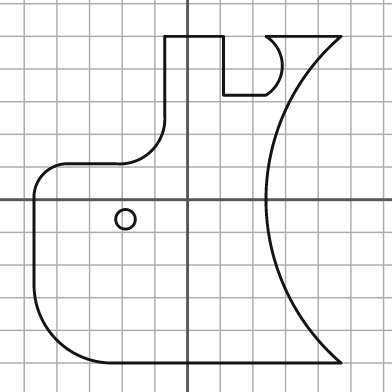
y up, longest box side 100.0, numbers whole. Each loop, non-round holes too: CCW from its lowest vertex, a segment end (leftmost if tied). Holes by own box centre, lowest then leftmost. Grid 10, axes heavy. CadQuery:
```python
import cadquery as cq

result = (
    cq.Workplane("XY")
    .moveTo(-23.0, -50.0)
    .lineTo(47.0, -50.0)
    .threePointArc((24.0, 0.0), (47.0, 50.0))
    .lineTo(24.0, 50.0)
    .threePointArc((29.0, 41.0), (24.0, 32.0))
    .lineTo(11.0, 32.0)
    .lineTo(11.0, 50.0)
    .lineTo(-7.0, 50.0)
    .lineTo(-7.0, 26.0)
    .threePointArc((-11.0, 15.0), (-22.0, 11.0))
    .lineTo(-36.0, 11.0)
    .threePointArc((-44.0, 8.0), (-47.0, 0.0))
    .lineTo(-47.0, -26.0)
    .threePointArc((-40.0, -43.0), (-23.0, -50.0))
    .close()
    .moveTo(-19.0, -6.0)
    .circle(3.0)
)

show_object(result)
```